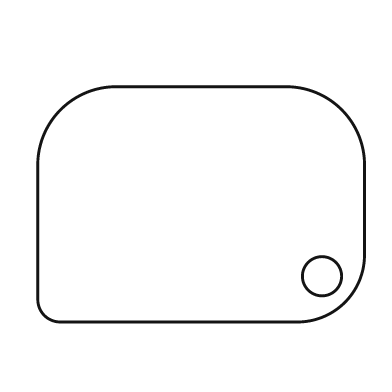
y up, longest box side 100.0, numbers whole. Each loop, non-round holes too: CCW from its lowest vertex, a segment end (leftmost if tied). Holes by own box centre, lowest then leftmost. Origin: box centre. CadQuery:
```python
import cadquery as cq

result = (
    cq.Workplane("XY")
    .moveTo(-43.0, -36.0)
    .lineTo(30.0, -36.0)
    .threePointArc((44.0, -30.0), (50.0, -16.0))
    .lineTo(50.0, 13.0)
    .threePointArc((43.0, 29.0), (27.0, 36.0))
    .lineTo(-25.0, 36.0)
    .threePointArc((-43.0, 29.0), (-50.0, 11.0))
    .lineTo(-50.0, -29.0)
    .threePointArc((-48.0, -34.0), (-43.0, -36.0))
    .close()
    .moveTo(37.0, -22.0)
    .circle(6.0)
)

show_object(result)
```